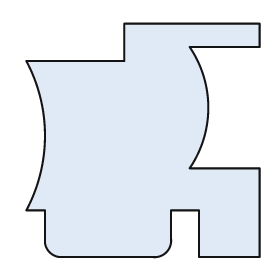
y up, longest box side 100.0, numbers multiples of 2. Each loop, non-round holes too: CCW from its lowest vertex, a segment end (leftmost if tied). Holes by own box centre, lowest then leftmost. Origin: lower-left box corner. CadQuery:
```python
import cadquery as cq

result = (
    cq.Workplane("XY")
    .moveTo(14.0, 0.0)
    .lineTo(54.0, 0.0)
    .threePointArc((60.0, 2.0), (62.0, 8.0))
    .lineTo(62.0, 20.0)
    .lineTo(74.0, 20.0)
    .lineTo(74.0, 0.0)
    .lineTo(100.0, 0.0)
    .lineTo(100.0, 38.0)
    .lineTo(70.0, 38.0)
    .threePointArc((78.0, 64.0), (70.0, 90.0))
    .lineTo(100.0, 90.0)
    .lineTo(100.0, 100.0)
    .lineTo(42.0, 100.0)
    .lineTo(42.0, 84.0)
    .lineTo(0.0, 84.0)
    .threePointArc((8.0, 52.0), (0.0, 20.0))
    .lineTo(8.0, 20.0)
    .lineTo(8.0, 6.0)
    .threePointArc((10.0, 2.0), (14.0, 0.0))
    .close()
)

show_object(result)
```